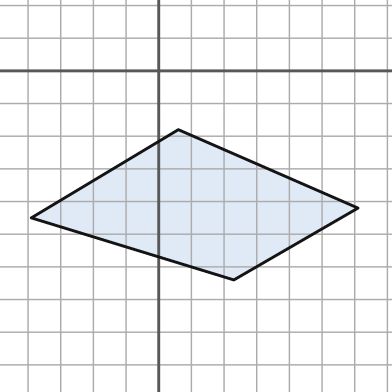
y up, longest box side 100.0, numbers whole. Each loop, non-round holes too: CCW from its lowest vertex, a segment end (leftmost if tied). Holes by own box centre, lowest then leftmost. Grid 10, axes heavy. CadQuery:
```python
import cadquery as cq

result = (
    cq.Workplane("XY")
    .moveTo(23.0, -64.0)
    .lineTo(61.0, -42.0)
    .lineTo(6.0, -18.0)
    .lineTo(-39.0, -45.0)
    .close()
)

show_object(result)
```